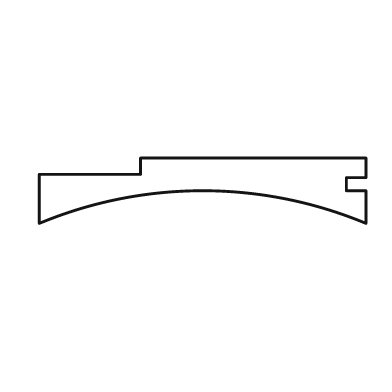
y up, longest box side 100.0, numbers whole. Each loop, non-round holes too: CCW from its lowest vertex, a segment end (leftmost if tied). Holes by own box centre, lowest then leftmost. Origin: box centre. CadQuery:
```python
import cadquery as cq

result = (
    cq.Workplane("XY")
    .moveTo(-50.0, -10.0)
    .threePointArc((0.0, 0.0), (50.0, -10.0))
    .lineTo(50.0, 0.0)
    .lineTo(44.0, 0.0)
    .lineTo(44.0, 4.0)
    .lineTo(50.0, 4.0)
    .lineTo(50.0, 10.0)
    .lineTo(-19.0, 10.0)
    .lineTo(-19.0, 5.0)
    .lineTo(-50.0, 5.0)
    .close()
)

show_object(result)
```